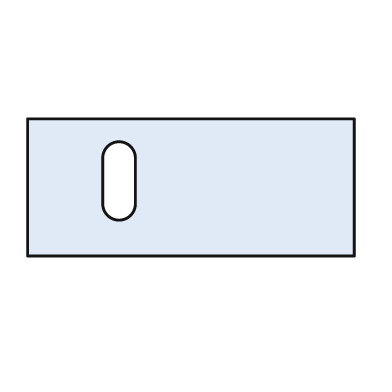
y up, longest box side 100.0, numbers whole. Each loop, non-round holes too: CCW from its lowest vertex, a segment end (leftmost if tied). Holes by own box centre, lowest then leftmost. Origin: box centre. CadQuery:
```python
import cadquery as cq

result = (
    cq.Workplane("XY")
    .moveTo(-50.0, -21.0)
    .lineTo(50.0, -21.0)
    .lineTo(50.0, 21.0)
    .lineTo(-50.0, 21.0)
    .close()
    .moveTo(-27.0, -5.0)
    .threePointArc((-22.0, -10.0), (-17.0, -5.0))
    .lineTo(-17.0, 9.0)
    .threePointArc((-22.0, 14.0), (-27.0, 9.0))
    .close()
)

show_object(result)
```